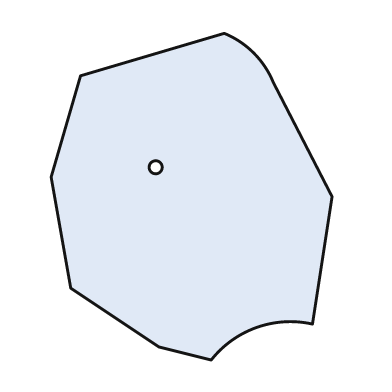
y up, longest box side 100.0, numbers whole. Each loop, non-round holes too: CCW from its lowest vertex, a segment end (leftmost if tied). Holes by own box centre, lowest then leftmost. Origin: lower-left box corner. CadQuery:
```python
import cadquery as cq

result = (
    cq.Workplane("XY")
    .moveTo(49.0, 0.0)
    .threePointArc((63.0, 10.0), (80.0, 11.0))
    .lineTo(86.0, 50.0)
    .lineTo(68.0, 85.0)
    .threePointArc((62.0, 94.0), (53.0, 100.0))
    .lineTo(9.0, 87.0)
    .lineTo(0.0, 56.0)
    .lineTo(6.0, 22.0)
    .lineTo(33.0, 4.0)
    .close()
    .moveTo(32.0, 59.0)
    .circle(2.0)
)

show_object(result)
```